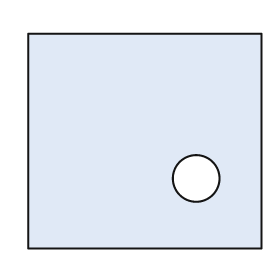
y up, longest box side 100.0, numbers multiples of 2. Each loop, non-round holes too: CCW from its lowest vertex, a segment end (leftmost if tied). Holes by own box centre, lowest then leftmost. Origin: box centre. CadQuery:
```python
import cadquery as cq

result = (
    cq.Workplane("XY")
    .moveTo(-50.0, -46.0)
    .lineTo(50.0, -46.0)
    .lineTo(50.0, 46.0)
    .lineTo(-50.0, 46.0)
    .close()
    .moveTo(22.0, -16.0)
    .circle(10.0)
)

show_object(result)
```